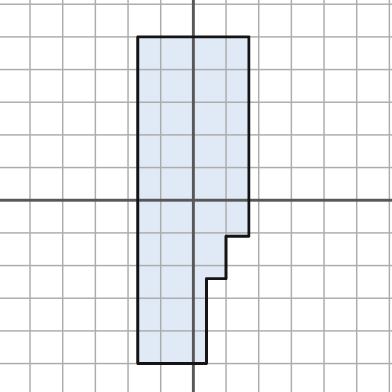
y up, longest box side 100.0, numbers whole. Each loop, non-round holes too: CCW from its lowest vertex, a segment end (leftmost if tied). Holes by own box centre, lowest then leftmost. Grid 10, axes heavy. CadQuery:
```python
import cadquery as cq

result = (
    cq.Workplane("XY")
    .moveTo(-17.0, -50.0)
    .lineTo(4.0, -50.0)
    .lineTo(4.0, -24.0)
    .lineTo(10.0, -24.0)
    .lineTo(10.0, -11.0)
    .lineTo(17.0, -11.0)
    .lineTo(17.0, 50.0)
    .lineTo(-17.0, 50.0)
    .close()
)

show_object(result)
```